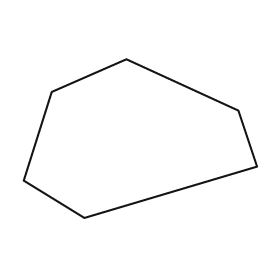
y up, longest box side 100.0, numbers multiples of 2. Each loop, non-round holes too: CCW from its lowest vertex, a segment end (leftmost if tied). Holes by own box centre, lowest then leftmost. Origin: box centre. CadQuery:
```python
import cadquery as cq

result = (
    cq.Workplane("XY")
    .moveTo(-24.0, -34.0)
    .lineTo(50.0, -12.0)
    .lineTo(42.0, 12.0)
    .lineTo(-6.0, 34.0)
    .lineTo(-38.0, 20.0)
    .lineTo(-50.0, -18.0)
    .close()
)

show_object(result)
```